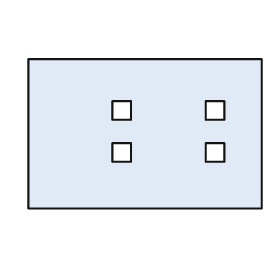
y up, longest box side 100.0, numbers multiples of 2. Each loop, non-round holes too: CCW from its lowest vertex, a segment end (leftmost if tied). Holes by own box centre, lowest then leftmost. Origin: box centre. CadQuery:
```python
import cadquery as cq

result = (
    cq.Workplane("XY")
    .moveTo(-50.0, -32.0)
    .lineTo(50.0, -32.0)
    .lineTo(50.0, 32.0)
    .lineTo(-50.0, 32.0)
    .close()
    .moveTo(-14.0, -12.0)
    .lineTo(-6.0, -12.0)
    .lineTo(-6.0, -4.0)
    .lineTo(-14.0, -4.0)
    .close()
    .moveTo(26.0, -12.0)
    .lineTo(34.0, -12.0)
    .lineTo(34.0, -4.0)
    .lineTo(26.0, -4.0)
    .close()
    .moveTo(-14.0, 6.0)
    .lineTo(-6.0, 6.0)
    .lineTo(-6.0, 14.0)
    .lineTo(-14.0, 14.0)
    .close()
    .moveTo(26.0, 6.0)
    .lineTo(34.0, 6.0)
    .lineTo(34.0, 14.0)
    .lineTo(26.0, 14.0)
    .close()
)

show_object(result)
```